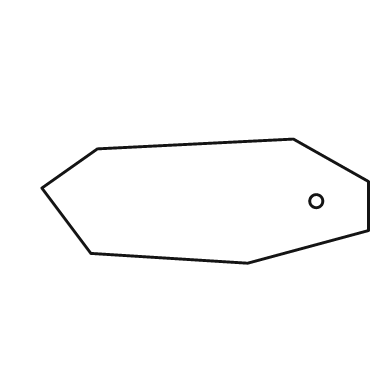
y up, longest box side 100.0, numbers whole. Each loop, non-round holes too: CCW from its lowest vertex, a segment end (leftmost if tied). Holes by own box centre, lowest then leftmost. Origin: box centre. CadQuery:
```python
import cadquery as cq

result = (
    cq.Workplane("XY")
    .moveTo(13.0, -19.0)
    .lineTo(50.0, -9.0)
    .lineTo(50.0, 6.0)
    .lineTo(27.0, 19.0)
    .lineTo(-33.0, 16.0)
    .lineTo(-50.0, 4.0)
    .lineTo(-35.0, -16.0)
    .close()
    .moveTo(34.0, 0.0)
    .circle(2.0)
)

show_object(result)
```